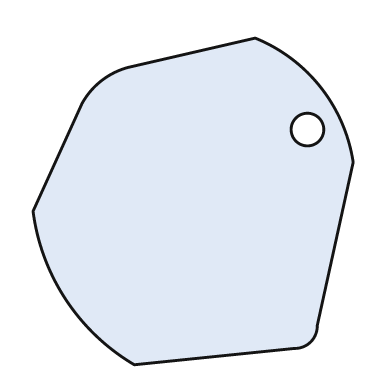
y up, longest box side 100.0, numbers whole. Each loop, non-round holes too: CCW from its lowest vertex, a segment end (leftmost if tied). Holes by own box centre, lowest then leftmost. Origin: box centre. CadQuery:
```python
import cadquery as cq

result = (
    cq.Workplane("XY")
    .moveTo(-18.0, -50.0)
    .lineTo(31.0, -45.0)
    .threePointArc((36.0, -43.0), (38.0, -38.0))
    .lineTo(49.0, 12.0)
    .threePointArc((39.0, 35.0), (19.0, 50.0))
    .lineTo(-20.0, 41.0)
    .threePointArc((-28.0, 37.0), (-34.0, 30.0))
    .lineTo(-49.0, -3.0)
    .threePointArc((-39.0, -30.0), (-18.0, -50.0))
    .close()
    .moveTo(35.0, 22.0)
    .circle(5.0)
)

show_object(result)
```